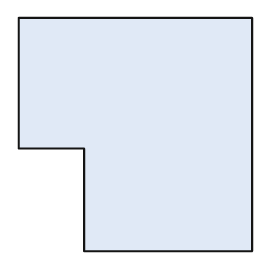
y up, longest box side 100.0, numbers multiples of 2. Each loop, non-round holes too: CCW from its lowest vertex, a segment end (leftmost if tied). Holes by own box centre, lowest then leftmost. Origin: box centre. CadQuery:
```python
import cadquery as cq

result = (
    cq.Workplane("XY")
    .moveTo(-22.0, -50.0)
    .lineTo(50.0, -50.0)
    .lineTo(50.0, 50.0)
    .lineTo(-50.0, 50.0)
    .lineTo(-50.0, -6.0)
    .lineTo(-22.0, -6.0)
    .close()
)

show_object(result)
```